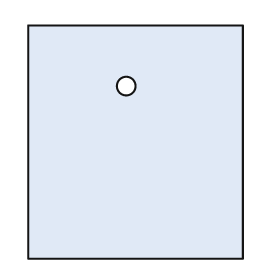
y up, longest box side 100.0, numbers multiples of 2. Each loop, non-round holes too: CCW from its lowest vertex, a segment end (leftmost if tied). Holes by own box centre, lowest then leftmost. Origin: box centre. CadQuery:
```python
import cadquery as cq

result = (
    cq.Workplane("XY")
    .moveTo(-46.0, -50.0)
    .lineTo(46.0, -50.0)
    .lineTo(46.0, 50.0)
    .lineTo(-46.0, 50.0)
    .close()
    .moveTo(-4.0, 24.0)
    .circle(4.0)
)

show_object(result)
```